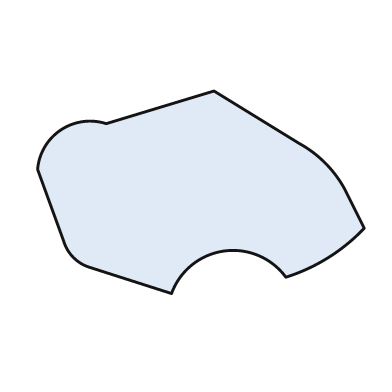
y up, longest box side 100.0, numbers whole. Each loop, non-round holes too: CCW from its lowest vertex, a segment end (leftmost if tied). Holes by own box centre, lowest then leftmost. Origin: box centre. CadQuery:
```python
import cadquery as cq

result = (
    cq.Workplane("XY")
    .moveTo(-9.0, -31.0)
    .threePointArc((7.0, -18.0), (26.0, -26.0))
    .threePointArc((39.0, -20.0), (50.0, -11.0))
    .lineTo(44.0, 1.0)
    .threePointArc((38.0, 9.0), (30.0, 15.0))
    .lineTo(4.0, 31.0)
    .lineTo(-29.0, 21.0)
    .threePointArc((-43.0, 19.0), (-50.0, 7.0))
    .lineTo(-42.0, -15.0)
    .threePointArc((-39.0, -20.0), (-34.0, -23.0))
    .close()
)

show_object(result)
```